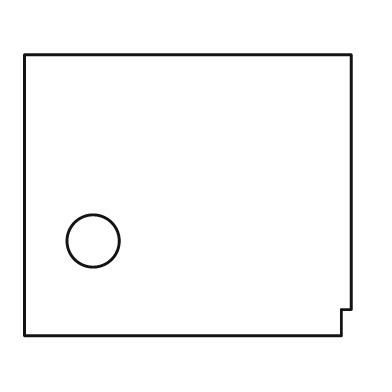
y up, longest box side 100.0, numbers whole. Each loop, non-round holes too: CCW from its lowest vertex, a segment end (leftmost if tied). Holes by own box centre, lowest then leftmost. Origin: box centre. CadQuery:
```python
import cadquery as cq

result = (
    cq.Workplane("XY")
    .moveTo(-50.0, -43.0)
    .lineTo(47.0, -43.0)
    .lineTo(47.0, -35.0)
    .lineTo(50.0, -35.0)
    .lineTo(50.0, 43.0)
    .lineTo(-50.0, 43.0)
    .close()
    .moveTo(-29.0, -14.0)
    .circle(8.0)
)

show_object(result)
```